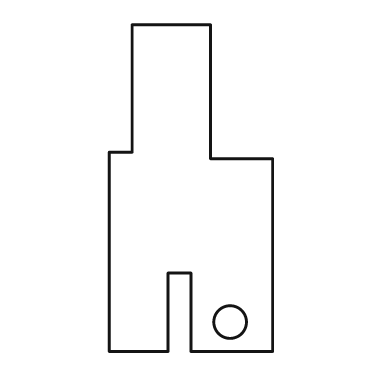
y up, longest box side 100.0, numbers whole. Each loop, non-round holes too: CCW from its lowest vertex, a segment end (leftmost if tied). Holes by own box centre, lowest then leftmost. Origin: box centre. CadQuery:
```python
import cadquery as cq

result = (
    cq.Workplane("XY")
    .moveTo(-25.0, -50.0)
    .lineTo(-7.0, -50.0)
    .lineTo(-7.0, -26.0)
    .lineTo(0.0, -26.0)
    .lineTo(0.0, -50.0)
    .lineTo(25.0, -50.0)
    .lineTo(25.0, 9.0)
    .lineTo(6.0, 9.0)
    .lineTo(6.0, 50.0)
    .lineTo(-18.0, 50.0)
    .lineTo(-18.0, 11.0)
    .lineTo(-25.0, 11.0)
    .close()
    .moveTo(12.0, -41.0)
    .circle(5.0)
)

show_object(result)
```